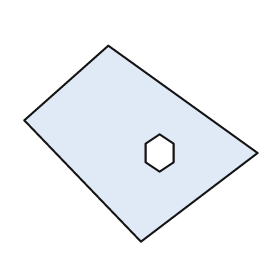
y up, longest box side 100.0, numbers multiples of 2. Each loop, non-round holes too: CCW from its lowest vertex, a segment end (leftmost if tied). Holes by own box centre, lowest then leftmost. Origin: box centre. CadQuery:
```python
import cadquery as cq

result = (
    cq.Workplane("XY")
    .moveTo(0.0, -42.0)
    .lineTo(50.0, -4.0)
    .lineTo(-14.0, 42.0)
    .lineTo(-50.0, 10.0)
    .close()
    .moveTo(8.0, -12.0)
    .lineTo(14.0, -8.0)
    .lineTo(14.0, 0.0)
    .lineTo(8.0, 4.0)
    .lineTo(2.0, 0.0)
    .lineTo(2.0, -8.0)
    .close()
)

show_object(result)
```